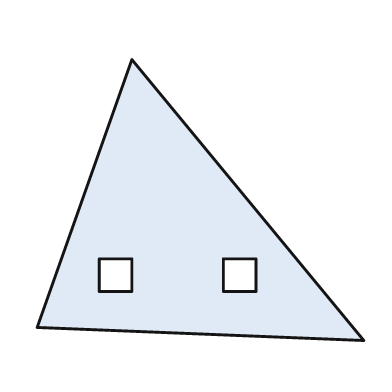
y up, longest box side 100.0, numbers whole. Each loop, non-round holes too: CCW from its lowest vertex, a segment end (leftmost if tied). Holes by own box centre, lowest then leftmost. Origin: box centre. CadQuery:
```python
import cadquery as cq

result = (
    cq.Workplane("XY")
    .moveTo(50.0, -43.0)
    .lineTo(-21.0, 43.0)
    .lineTo(-50.0, -39.0)
    .close()
    .moveTo(-31.0, -28.0)
    .lineTo(-21.0, -28.0)
    .lineTo(-21.0, -18.0)
    .lineTo(-31.0, -18.0)
    .close()
    .moveTo(7.0, -28.0)
    .lineTo(17.0, -28.0)
    .lineTo(17.0, -18.0)
    .lineTo(7.0, -18.0)
    .close()
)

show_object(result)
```